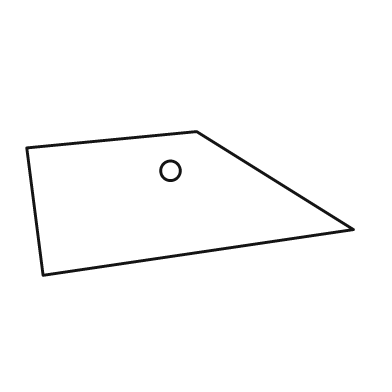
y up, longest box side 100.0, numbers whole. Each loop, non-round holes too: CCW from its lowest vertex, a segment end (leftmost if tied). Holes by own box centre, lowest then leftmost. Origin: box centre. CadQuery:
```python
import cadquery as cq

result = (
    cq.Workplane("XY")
    .moveTo(-45.0, -22.0)
    .lineTo(50.0, -8.0)
    .lineTo(2.0, 22.0)
    .lineTo(-50.0, 17.0)
    .close()
    .moveTo(-6.0, 10.0)
    .circle(3.0)
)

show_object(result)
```